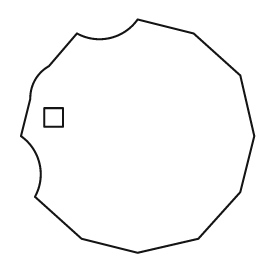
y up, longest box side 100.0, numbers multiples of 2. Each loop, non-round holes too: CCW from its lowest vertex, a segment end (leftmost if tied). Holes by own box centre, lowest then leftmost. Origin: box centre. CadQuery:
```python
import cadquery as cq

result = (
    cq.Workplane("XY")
    .moveTo(0.0, -50.0)
    .lineTo(26.0, -44.0)
    .lineTo(44.0, -24.0)
    .lineTo(50.0, 0.0)
    .lineTo(44.0, 26.0)
    .lineTo(24.0, 44.0)
    .lineTo(0.0, 50.0)
    .threePointArc((-12.0, 42.0), (-26.0, 44.0))
    .lineTo(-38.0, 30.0)
    .threePointArc((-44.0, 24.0), (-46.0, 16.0))
    .lineTo(-50.0, 0.0)
    .threePointArc((-42.0, -12.0), (-44.0, -26.0))
    .lineTo(-24.0, -44.0)
    .close()
    .moveTo(-40.0, 4.0)
    .lineTo(-32.0, 4.0)
    .lineTo(-32.0, 12.0)
    .lineTo(-40.0, 12.0)
    .close()
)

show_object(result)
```